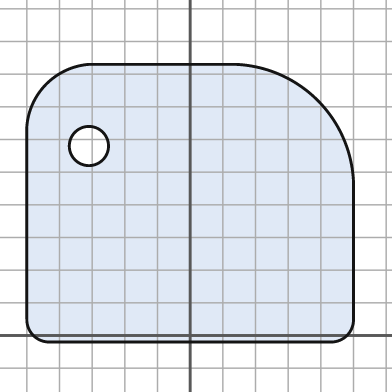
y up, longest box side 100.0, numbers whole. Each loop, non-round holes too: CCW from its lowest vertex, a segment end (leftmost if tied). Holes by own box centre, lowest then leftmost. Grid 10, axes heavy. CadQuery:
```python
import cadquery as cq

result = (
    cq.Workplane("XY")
    .moveTo(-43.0, -2.0)
    .lineTo(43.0, -2.0)
    .threePointArc((48.0, 0.0), (50.0, 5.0))
    .lineTo(50.0, 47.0)
    .threePointArc((39.0, 72.0), (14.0, 83.0))
    .lineTo(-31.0, 83.0)
    .threePointArc((-44.0, 77.0), (-50.0, 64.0))
    .lineTo(-50.0, 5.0)
    .threePointArc((-48.0, 0.0), (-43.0, -2.0))
    .close()
    .moveTo(-31.0, 58.0)
    .circle(6.0)
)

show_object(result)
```